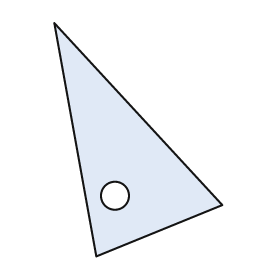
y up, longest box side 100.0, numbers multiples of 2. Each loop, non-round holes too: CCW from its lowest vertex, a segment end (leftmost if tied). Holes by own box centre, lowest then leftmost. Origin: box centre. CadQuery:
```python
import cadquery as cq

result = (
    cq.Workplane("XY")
    .moveTo(-18.0, -50.0)
    .lineTo(36.0, -28.0)
    .lineTo(-36.0, 50.0)
    .close()
    .moveTo(-10.0, -24.0)
    .circle(6.0)
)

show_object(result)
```